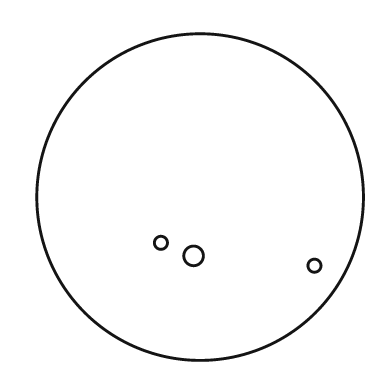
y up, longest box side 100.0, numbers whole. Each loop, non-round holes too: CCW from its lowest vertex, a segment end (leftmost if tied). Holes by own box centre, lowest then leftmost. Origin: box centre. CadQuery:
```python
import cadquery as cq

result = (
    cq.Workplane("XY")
    .moveTo(0.0, 0.0)
    .circle(50.0)
    .moveTo(35.0, -21.0)
    .circle(2.0)
    .moveTo(-2.0, -18.0)
    .circle(3.0)
    .moveTo(-12.0, -14.0)
    .circle(2.0)
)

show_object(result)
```